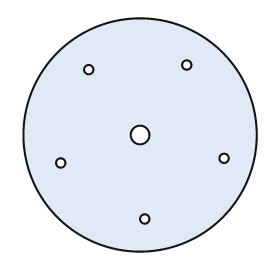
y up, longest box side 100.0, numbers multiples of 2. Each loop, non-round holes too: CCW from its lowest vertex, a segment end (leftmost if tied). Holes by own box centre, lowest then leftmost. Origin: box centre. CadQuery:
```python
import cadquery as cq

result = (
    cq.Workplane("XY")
    .moveTo(0.0, 0.0)
    .circle(50.0)
    .moveTo(2.0, -36.0)
    .circle(2.0)
    .moveTo(-34.0, -12.0)
    .circle(2.0)
    .moveTo(36.0, -10.0)
    .circle(2.0)
    .moveTo(0.0, 0.0)
    .circle(4.0)
    .moveTo(-22.0, 28.0)
    .circle(2.0)
    .moveTo(20.0, 30.0)
    .circle(2.0)
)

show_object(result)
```